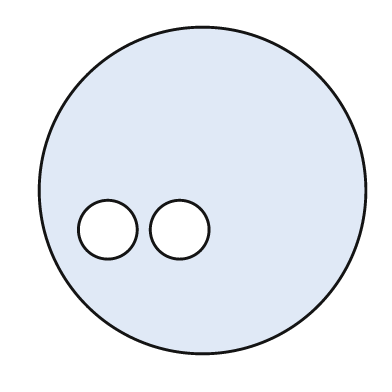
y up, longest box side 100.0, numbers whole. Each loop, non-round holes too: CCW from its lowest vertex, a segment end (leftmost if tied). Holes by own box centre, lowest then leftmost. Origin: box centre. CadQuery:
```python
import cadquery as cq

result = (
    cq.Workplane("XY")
    .moveTo(0.0, 0.0)
    .circle(50.0)
    .moveTo(-29.0, -12.0)
    .circle(9.0)
    .moveTo(-7.0, -12.0)
    .circle(9.0)
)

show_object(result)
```